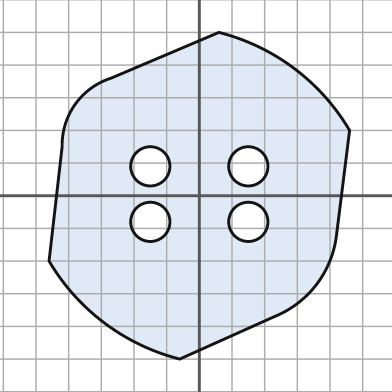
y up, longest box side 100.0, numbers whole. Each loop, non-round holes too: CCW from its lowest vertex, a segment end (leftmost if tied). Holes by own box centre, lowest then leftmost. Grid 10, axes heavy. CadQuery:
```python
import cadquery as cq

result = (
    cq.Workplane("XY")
    .moveTo(-6.0, -50.0)
    .lineTo(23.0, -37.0)
    .threePointArc((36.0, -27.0), (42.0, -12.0))
    .lineTo(46.0, 20.0)
    .threePointArc((29.0, 39.0), (6.0, 50.0))
    .lineTo(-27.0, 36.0)
    .threePointArc((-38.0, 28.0), (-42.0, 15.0))
    .lineTo(-46.0, -20.0)
    .threePointArc((-29.0, -39.0), (-6.0, -50.0))
    .close()
    .moveTo(-15.0, -8.0)
    .circle(6.0)
    .moveTo(15.0, -8.0)
    .circle(6.0)
    .moveTo(-15.0, 9.0)
    .circle(6.0)
    .moveTo(15.0, 9.0)
    .circle(6.0)
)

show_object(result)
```